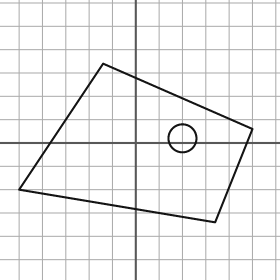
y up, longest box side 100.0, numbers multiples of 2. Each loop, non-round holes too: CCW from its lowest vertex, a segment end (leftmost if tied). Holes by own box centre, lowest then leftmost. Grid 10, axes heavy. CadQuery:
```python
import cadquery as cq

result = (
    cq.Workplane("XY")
    .moveTo(34.0, -34.0)
    .lineTo(50.0, 6.0)
    .lineTo(-14.0, 34.0)
    .lineTo(-50.0, -20.0)
    .close()
    .moveTo(20.0, 2.0)
    .circle(6.0)
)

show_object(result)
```